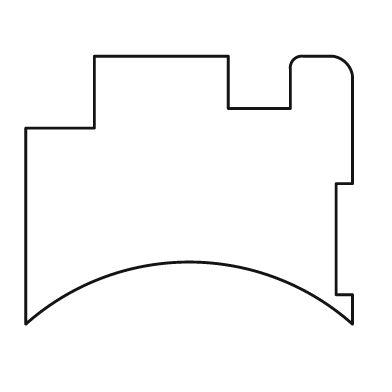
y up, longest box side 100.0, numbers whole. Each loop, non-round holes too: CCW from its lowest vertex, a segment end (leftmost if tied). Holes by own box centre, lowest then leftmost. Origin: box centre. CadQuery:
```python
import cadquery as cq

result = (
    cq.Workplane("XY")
    .moveTo(-50.0, -41.0)
    .threePointArc((0.0, -22.0), (50.0, -41.0))
    .lineTo(50.0, -32.0)
    .lineTo(45.0, -32.0)
    .lineTo(45.0, 2.0)
    .lineTo(50.0, 2.0)
    .lineTo(50.0, 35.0)
    .threePointArc((48.0, 39.0), (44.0, 41.0))
    .lineTo(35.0, 41.0)
    .threePointArc((32.0, 40.0), (31.0, 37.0))
    .lineTo(31.0, 25.0)
    .lineTo(12.0, 25.0)
    .lineTo(12.0, 41.0)
    .lineTo(-29.0, 41.0)
    .lineTo(-29.0, 19.0)
    .lineTo(-50.0, 19.0)
    .close()
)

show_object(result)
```